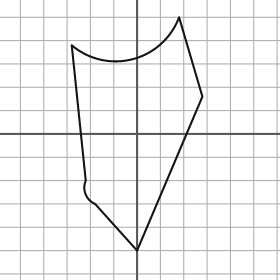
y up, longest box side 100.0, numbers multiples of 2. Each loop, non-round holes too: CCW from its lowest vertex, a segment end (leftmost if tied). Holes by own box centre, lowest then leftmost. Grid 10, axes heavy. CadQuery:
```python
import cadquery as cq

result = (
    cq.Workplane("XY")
    .moveTo(0.0, -50.0)
    .lineTo(28.0, 16.0)
    .lineTo(18.0, 50.0)
    .threePointArc((-2.0, 32.0), (-28.0, 38.0))
    .lineTo(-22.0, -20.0)
    .threePointArc((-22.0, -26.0), (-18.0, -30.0))
    .close()
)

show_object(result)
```